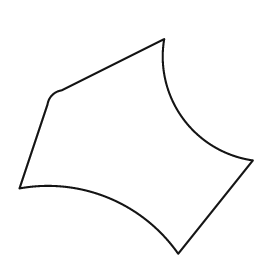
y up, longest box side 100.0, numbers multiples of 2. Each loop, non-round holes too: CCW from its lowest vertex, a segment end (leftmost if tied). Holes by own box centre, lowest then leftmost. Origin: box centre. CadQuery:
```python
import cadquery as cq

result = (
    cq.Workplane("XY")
    .moveTo(18.0, -46.0)
    .lineTo(50.0, -6.0)
    .threePointArc((20.0, 12.0), (12.0, 46.0))
    .lineTo(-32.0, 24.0)
    .threePointArc((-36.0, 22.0), (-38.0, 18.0))
    .lineTo(-50.0, -18.0)
    .threePointArc((-12.0, -22.0), (18.0, -46.0))
    .close()
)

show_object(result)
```